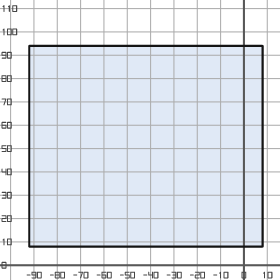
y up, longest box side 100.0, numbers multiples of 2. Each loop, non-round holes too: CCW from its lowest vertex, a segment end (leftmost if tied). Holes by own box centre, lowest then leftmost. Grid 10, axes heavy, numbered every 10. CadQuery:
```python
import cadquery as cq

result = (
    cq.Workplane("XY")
    .moveTo(-92.0, 8.0)
    .lineTo(8.0, 8.0)
    .lineTo(8.0, 94.0)
    .lineTo(-92.0, 94.0)
    .close()
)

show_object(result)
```